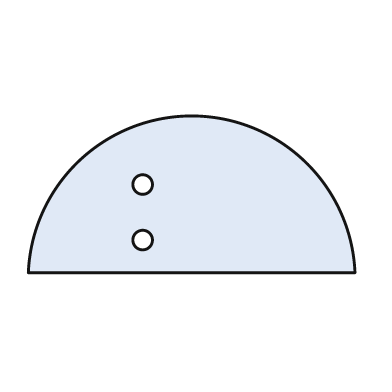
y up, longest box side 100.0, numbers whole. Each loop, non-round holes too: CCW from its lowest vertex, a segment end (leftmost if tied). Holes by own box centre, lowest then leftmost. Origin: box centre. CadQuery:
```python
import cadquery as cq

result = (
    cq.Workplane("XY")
    .moveTo(-50.0, -24.0)
    .lineTo(50.0, -24.0)
    .threePointArc((0.0, 24.0), (-50.0, -24.0))
    .close()
    .moveTo(-15.0, -14.0)
    .circle(3.0)
    .moveTo(-15.0, 3.0)
    .circle(3.0)
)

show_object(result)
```